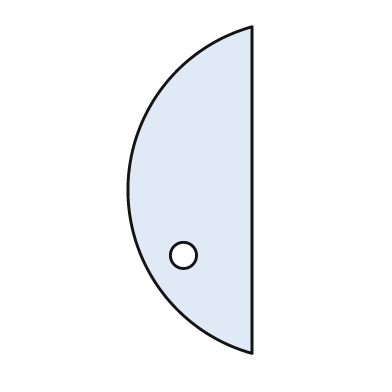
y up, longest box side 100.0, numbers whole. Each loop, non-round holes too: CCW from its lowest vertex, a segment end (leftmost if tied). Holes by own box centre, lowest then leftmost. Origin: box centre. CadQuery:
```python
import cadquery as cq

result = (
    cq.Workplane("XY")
    .moveTo(19.0, -50.0)
    .lineTo(19.0, 50.0)
    .threePointArc((-19.0, 0.0), (19.0, -50.0))
    .close()
    .moveTo(-2.0, -20.0)
    .circle(4.0)
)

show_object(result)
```